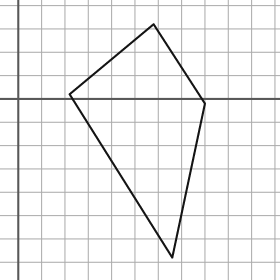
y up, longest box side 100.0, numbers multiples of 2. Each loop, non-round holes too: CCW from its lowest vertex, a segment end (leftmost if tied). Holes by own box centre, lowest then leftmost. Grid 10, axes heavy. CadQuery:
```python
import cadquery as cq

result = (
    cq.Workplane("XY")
    .moveTo(66.0, -68.0)
    .lineTo(80.0, -2.0)
    .lineTo(58.0, 32.0)
    .lineTo(22.0, 2.0)
    .close()
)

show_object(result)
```